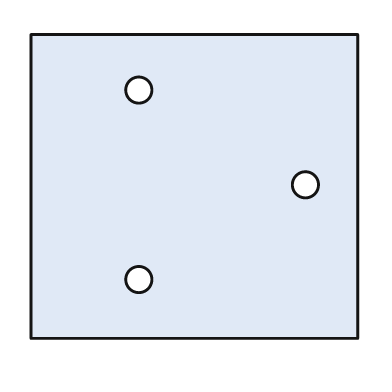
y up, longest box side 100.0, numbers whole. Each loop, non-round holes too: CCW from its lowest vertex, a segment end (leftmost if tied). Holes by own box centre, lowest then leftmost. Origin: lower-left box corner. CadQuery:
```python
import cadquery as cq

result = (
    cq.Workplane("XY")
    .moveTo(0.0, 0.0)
    .lineTo(100.0, 0.0)
    .lineTo(100.0, 93.0)
    .lineTo(0.0, 93.0)
    .close()
    .moveTo(33.0, 18.0)
    .circle(4.0)
    .moveTo(84.0, 47.0)
    .circle(4.0)
    .moveTo(33.0, 76.0)
    .circle(4.0)
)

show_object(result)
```